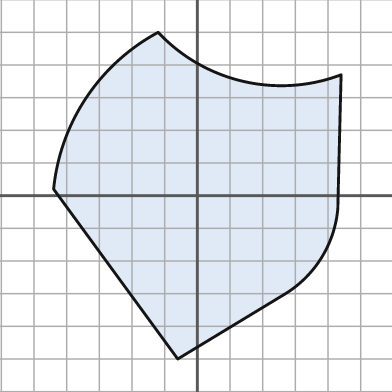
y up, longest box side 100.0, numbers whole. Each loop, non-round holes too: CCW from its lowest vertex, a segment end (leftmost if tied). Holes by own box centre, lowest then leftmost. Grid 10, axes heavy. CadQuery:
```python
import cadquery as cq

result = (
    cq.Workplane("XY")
    .moveTo(-6.0, -50.0)
    .lineTo(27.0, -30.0)
    .threePointArc((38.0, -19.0), (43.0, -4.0))
    .lineTo(44.0, 37.0)
    .threePointArc((14.0, 35.0), (-12.0, 50.0))
    .threePointArc((-34.0, 30.0), (-44.0, 2.0))
    .close()
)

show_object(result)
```